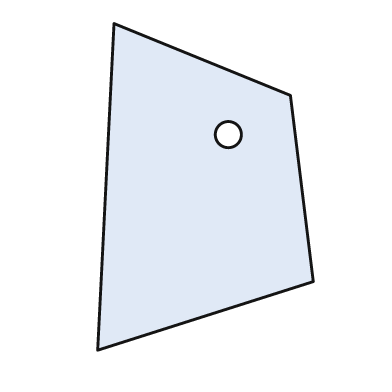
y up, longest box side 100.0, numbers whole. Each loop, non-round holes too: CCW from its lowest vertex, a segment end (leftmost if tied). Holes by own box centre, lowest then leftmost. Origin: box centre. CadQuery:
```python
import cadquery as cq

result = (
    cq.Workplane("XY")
    .moveTo(-33.0, -50.0)
    .lineTo(33.0, -29.0)
    .lineTo(26.0, 28.0)
    .lineTo(-28.0, 50.0)
    .close()
    .moveTo(7.0, 16.0)
    .circle(4.0)
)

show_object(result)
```